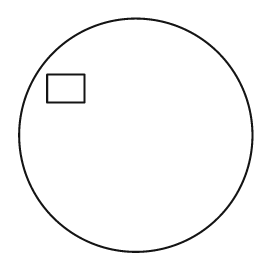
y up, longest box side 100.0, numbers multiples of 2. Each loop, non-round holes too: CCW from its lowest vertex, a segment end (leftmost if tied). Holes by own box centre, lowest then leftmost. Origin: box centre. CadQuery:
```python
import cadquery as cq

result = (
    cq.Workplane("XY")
    .moveTo(0.0, 0.0)
    .circle(50.0)
    .moveTo(-38.0, 14.0)
    .lineTo(-22.0, 14.0)
    .lineTo(-22.0, 26.0)
    .lineTo(-38.0, 26.0)
    .close()
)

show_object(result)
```